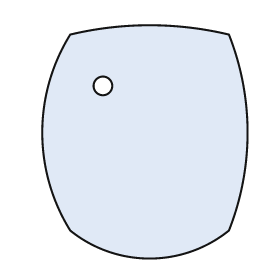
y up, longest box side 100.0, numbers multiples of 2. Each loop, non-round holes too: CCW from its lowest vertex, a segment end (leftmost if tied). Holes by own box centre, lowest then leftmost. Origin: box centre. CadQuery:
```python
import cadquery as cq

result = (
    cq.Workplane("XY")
    .moveTo(-32.0, -38.0)
    .threePointArc((2.0, -50.0), (36.0, -38.0))
    .threePointArc((44.0, 4.0), (36.0, 46.0))
    .threePointArc((2.0, 50.0), (-32.0, 46.0))
    .threePointArc((-44.0, 4.0), (-32.0, -38.0))
    .close()
    .moveTo(-18.0, 24.0)
    .circle(4.0)
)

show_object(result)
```